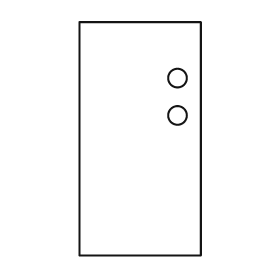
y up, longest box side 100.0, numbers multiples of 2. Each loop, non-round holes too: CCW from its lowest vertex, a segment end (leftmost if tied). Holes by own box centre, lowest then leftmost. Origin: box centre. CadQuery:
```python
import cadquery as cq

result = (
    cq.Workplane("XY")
    .moveTo(-26.0, -50.0)
    .lineTo(26.0, -50.0)
    .lineTo(26.0, 50.0)
    .lineTo(-26.0, 50.0)
    .close()
    .moveTo(16.0, 10.0)
    .circle(4.0)
    .moveTo(16.0, 26.0)
    .circle(4.0)
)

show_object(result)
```